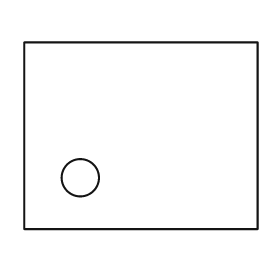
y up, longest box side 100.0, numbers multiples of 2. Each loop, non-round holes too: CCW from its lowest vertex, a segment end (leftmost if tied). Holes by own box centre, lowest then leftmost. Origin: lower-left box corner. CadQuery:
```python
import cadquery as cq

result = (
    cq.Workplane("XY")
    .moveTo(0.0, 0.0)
    .lineTo(100.0, 0.0)
    .lineTo(100.0, 80.0)
    .lineTo(0.0, 80.0)
    .close()
    .moveTo(24.0, 22.0)
    .circle(8.0)
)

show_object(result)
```